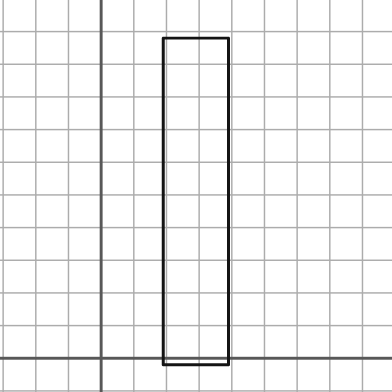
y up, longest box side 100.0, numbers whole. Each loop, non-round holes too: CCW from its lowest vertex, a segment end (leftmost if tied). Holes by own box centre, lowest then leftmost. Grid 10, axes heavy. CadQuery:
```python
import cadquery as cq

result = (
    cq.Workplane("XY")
    .moveTo(19.0, -2.0)
    .lineTo(39.0, -2.0)
    .lineTo(39.0, 98.0)
    .lineTo(19.0, 98.0)
    .close()
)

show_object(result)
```